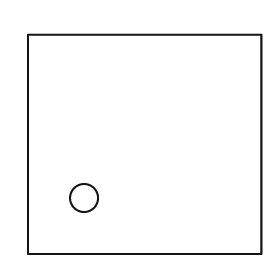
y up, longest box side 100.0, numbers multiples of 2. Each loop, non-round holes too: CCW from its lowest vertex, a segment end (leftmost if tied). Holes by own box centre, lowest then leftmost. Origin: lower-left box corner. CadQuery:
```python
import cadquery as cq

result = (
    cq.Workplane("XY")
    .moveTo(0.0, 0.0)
    .lineTo(100.0, 0.0)
    .lineTo(100.0, 94.0)
    .lineTo(0.0, 94.0)
    .close()
    .moveTo(24.0, 24.0)
    .circle(6.0)
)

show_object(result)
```